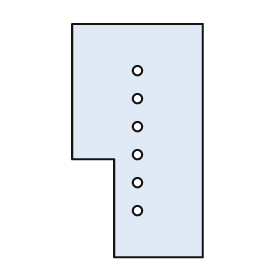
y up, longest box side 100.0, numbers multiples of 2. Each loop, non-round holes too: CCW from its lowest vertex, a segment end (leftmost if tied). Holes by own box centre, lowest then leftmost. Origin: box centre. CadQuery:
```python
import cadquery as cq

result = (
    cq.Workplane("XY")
    .moveTo(-10.0, -50.0)
    .lineTo(28.0, -50.0)
    .lineTo(28.0, 50.0)
    .lineTo(-28.0, 50.0)
    .lineTo(-28.0, -8.0)
    .lineTo(-10.0, -8.0)
    .close()
    .moveTo(0.0, -30.0)
    .circle(2.0)
    .moveTo(0.0, -18.0)
    .circle(2.0)
    .moveTo(0.0, -6.0)
    .circle(2.0)
    .moveTo(0.0, 6.0)
    .circle(2.0)
    .moveTo(0.0, 18.0)
    .circle(2.0)
    .moveTo(0.0, 30.0)
    .circle(2.0)
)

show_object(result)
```